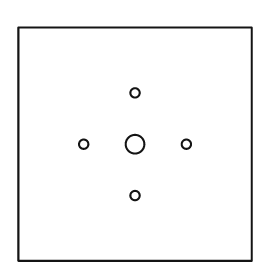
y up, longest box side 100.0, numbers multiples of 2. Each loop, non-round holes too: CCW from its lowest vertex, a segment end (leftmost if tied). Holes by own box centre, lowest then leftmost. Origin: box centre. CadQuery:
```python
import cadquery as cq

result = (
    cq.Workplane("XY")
    .moveTo(-50.0, -50.0)
    .lineTo(50.0, -50.0)
    .lineTo(50.0, 50.0)
    .lineTo(-50.0, 50.0)
    .close()
    .moveTo(0.0, -22.0)
    .circle(2.0)
    .moveTo(-22.0, 0.0)
    .circle(2.0)
    .moveTo(0.0, 0.0)
    .circle(4.0)
    .moveTo(22.0, 0.0)
    .circle(2.0)
    .moveTo(0.0, 22.0)
    .circle(2.0)
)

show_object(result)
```